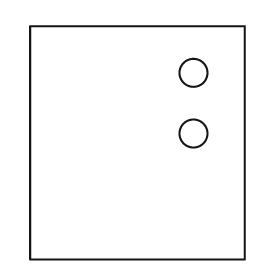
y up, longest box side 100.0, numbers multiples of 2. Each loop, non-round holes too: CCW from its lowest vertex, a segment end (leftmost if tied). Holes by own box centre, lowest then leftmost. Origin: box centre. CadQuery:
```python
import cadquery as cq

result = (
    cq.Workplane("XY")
    .moveTo(-46.0, -50.0)
    .lineTo(46.0, -50.0)
    .lineTo(46.0, 50.0)
    .lineTo(-46.0, 50.0)
    .close()
    .moveTo(24.0, 4.0)
    .circle(6.0)
    .moveTo(24.0, 30.0)
    .circle(6.0)
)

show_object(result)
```